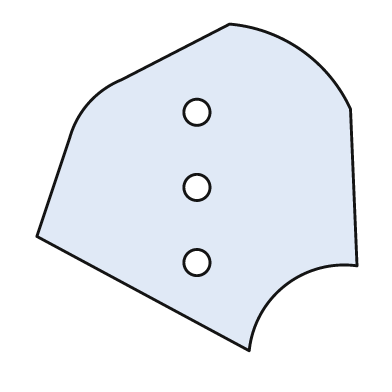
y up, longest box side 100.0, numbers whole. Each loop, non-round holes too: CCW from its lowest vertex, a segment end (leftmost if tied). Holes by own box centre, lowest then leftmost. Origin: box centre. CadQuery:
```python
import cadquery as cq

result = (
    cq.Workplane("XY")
    .moveTo(16.0, -50.0)
    .threePointArc((27.0, -30.0), (49.0, -24.0))
    .lineTo(47.0, 24.0)
    .threePointArc((32.0, 42.0), (10.0, 50.0))
    .lineTo(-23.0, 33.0)
    .threePointArc((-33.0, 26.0), (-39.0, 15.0))
    .lineTo(-49.0, -15.0)
    .close()
    .moveTo(0.0, -23.0)
    .circle(4.0)
    .moveTo(0.0, 0.0)
    .circle(4.0)
    .moveTo(0.0, 23.0)
    .circle(4.0)
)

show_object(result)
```